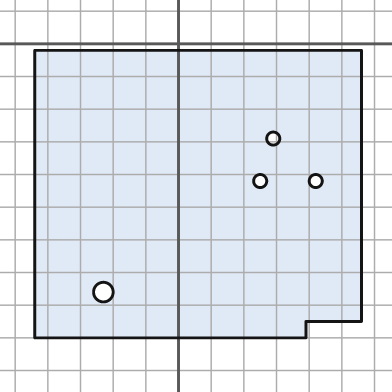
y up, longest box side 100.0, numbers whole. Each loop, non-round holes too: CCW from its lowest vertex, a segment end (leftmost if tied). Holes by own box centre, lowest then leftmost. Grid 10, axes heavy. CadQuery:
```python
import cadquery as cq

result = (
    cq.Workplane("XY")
    .moveTo(-44.0, -90.0)
    .lineTo(39.0, -90.0)
    .lineTo(39.0, -85.0)
    .lineTo(56.0, -85.0)
    .lineTo(56.0, -2.0)
    .lineTo(-44.0, -2.0)
    .close()
    .moveTo(-23.0, -76.0)
    .circle(3.0)
    .moveTo(25.0, -42.0)
    .circle(2.0)
    .moveTo(42.0, -42.0)
    .circle(2.0)
    .moveTo(29.0, -29.0)
    .circle(2.0)
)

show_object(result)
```